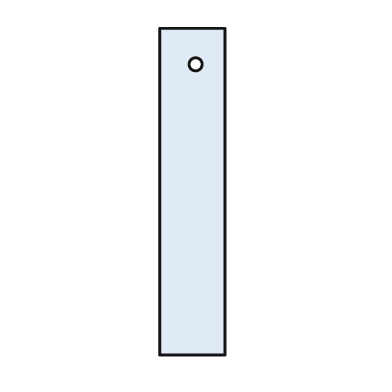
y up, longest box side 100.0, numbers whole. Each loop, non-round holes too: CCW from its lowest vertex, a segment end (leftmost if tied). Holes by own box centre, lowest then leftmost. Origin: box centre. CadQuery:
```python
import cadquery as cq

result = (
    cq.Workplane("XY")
    .moveTo(-10.0, -50.0)
    .lineTo(10.0, -50.0)
    .lineTo(10.0, 50.0)
    .lineTo(-10.0, 50.0)
    .close()
    .moveTo(1.0, 39.0)
    .circle(2.0)
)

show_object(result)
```